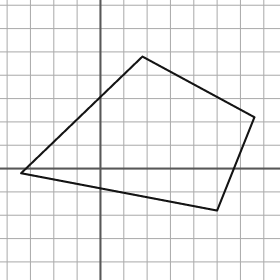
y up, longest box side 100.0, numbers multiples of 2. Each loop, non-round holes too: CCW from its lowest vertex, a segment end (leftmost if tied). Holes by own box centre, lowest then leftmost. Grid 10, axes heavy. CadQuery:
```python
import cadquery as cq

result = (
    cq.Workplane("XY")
    .moveTo(50.0, -18.0)
    .lineTo(66.0, 22.0)
    .lineTo(18.0, 48.0)
    .lineTo(-34.0, -2.0)
    .close()
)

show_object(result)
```